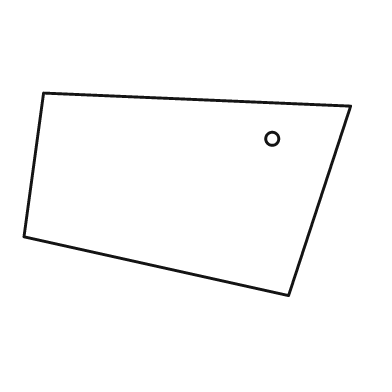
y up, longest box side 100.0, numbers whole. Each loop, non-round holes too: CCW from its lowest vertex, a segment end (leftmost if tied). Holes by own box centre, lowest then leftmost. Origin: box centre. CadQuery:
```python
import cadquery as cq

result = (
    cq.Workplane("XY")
    .moveTo(31.0, -31.0)
    .lineTo(50.0, 27.0)
    .lineTo(-44.0, 31.0)
    .lineTo(-50.0, -13.0)
    .close()
    .moveTo(26.0, 17.0)
    .circle(2.0)
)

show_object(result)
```